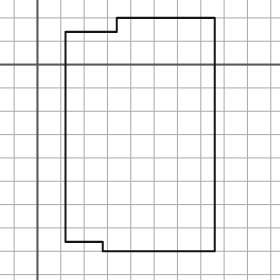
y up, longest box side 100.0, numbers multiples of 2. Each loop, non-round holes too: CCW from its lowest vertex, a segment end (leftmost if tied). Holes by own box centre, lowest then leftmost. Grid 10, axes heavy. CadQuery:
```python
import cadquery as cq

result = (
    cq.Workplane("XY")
    .moveTo(28.0, -80.0)
    .lineTo(76.0, -80.0)
    .lineTo(76.0, 20.0)
    .lineTo(34.0, 20.0)
    .lineTo(34.0, 14.0)
    .lineTo(12.0, 14.0)
    .lineTo(12.0, -76.0)
    .lineTo(28.0, -76.0)
    .close()
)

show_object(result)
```